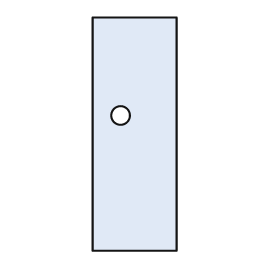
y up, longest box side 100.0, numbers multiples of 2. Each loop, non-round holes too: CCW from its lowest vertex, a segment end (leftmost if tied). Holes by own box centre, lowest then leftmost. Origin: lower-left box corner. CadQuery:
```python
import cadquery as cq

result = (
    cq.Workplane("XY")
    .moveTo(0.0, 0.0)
    .lineTo(36.0, 0.0)
    .lineTo(36.0, 100.0)
    .lineTo(0.0, 100.0)
    .close()
    .moveTo(12.0, 58.0)
    .circle(4.0)
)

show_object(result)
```